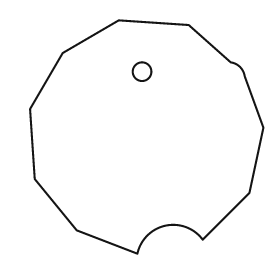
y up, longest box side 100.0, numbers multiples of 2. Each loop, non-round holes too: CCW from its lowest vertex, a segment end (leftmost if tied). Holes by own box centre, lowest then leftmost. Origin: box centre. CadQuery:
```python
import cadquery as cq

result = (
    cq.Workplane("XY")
    .moveTo(-4.0, -50.0)
    .threePointArc((8.0, -38.0), (24.0, -44.0))
    .lineTo(44.0, -24.0)
    .lineTo(50.0, 4.0)
    .lineTo(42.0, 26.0)
    .threePointArc((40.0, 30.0), (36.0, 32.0))
    .lineTo(18.0, 48.0)
    .lineTo(-12.0, 50.0)
    .lineTo(-36.0, 36.0)
    .lineTo(-50.0, 12.0)
    .lineTo(-48.0, -18.0)
    .lineTo(-30.0, -40.0)
    .close()
    .moveTo(-2.0, 28.0)
    .circle(4.0)
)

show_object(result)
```